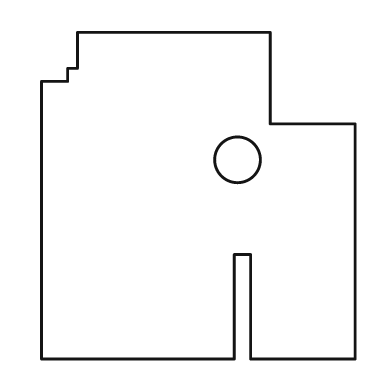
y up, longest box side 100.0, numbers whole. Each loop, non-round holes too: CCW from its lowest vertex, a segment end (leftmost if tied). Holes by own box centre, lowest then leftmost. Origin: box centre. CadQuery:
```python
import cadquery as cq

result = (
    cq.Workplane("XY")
    .moveTo(-48.0, -50.0)
    .lineTo(11.0, -50.0)
    .lineTo(11.0, -18.0)
    .lineTo(16.0, -18.0)
    .lineTo(16.0, -50.0)
    .lineTo(48.0, -50.0)
    .lineTo(48.0, 22.0)
    .lineTo(22.0, 22.0)
    .lineTo(22.0, 50.0)
    .lineTo(-37.0, 50.0)
    .lineTo(-37.0, 39.0)
    .lineTo(-40.0, 39.0)
    .lineTo(-40.0, 35.0)
    .lineTo(-48.0, 35.0)
    .close()
    .moveTo(12.0, 11.0)
    .circle(7.0)
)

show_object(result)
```